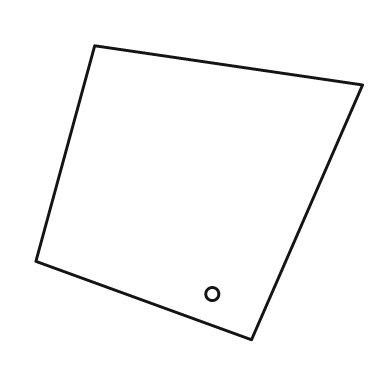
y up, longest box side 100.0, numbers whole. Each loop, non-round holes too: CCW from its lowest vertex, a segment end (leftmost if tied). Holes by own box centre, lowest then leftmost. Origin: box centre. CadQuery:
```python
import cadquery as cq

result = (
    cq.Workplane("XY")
    .moveTo(16.0, -45.0)
    .lineTo(50.0, 33.0)
    .lineTo(-32.0, 45.0)
    .lineTo(-50.0, -21.0)
    .close()
    .moveTo(4.0, -31.0)
    .circle(2.0)
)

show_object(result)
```